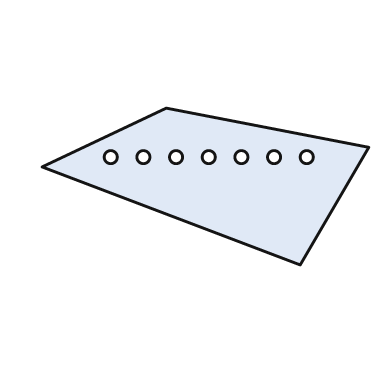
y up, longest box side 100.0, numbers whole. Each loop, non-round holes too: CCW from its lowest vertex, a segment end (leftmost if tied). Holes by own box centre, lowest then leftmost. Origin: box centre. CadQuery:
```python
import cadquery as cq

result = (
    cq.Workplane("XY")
    .moveTo(29.0, -24.0)
    .lineTo(50.0, 12.0)
    .lineTo(-12.0, 24.0)
    .lineTo(-50.0, 6.0)
    .close()
    .moveTo(-29.0, 9.0)
    .circle(2.0)
    .moveTo(-19.0, 9.0)
    .circle(2.0)
    .moveTo(-9.0, 9.0)
    .circle(2.0)
    .moveTo(1.0, 9.0)
    .circle(2.0)
    .moveTo(11.0, 9.0)
    .circle(2.0)
    .moveTo(21.0, 9.0)
    .circle(2.0)
    .moveTo(31.0, 9.0)
    .circle(2.0)
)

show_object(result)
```